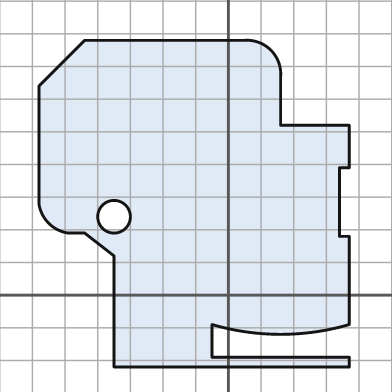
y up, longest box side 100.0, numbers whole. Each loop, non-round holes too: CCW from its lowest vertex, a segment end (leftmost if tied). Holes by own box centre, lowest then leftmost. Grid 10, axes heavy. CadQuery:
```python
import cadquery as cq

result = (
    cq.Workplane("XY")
    .moveTo(-35.0, -22.0)
    .lineTo(37.0, -22.0)
    .lineTo(37.0, -19.0)
    .lineTo(-5.0, -19.0)
    .lineTo(-5.0, -9.0)
    .threePointArc((16.0, -12.0), (37.0, -9.0))
    .lineTo(37.0, 18.0)
    .lineTo(34.0, 18.0)
    .lineTo(34.0, 39.0)
    .lineTo(37.0, 39.0)
    .lineTo(37.0, 52.0)
    .lineTo(16.0, 52.0)
    .lineTo(16.0, 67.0)
    .threePointArc((13.0, 75.0), (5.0, 78.0))
    .lineTo(-44.0, 78.0)
    .lineTo(-58.0, 64.0)
    .lineTo(-58.0, 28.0)
    .threePointArc((-55.0, 22.0), (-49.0, 19.0))
    .lineTo(-44.0, 19.0)
    .lineTo(-35.0, 12.0)
    .close()
    .moveTo(-35.0, 24.0)
    .circle(5.0)
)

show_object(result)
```